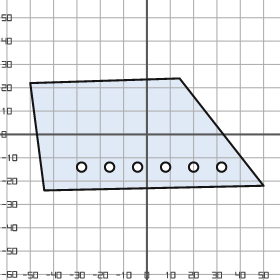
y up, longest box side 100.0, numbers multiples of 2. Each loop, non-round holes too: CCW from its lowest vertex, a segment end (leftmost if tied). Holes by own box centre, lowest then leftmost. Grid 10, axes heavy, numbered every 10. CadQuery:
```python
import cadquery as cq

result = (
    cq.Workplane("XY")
    .moveTo(-44.0, -24.0)
    .lineTo(50.0, -22.0)
    .lineTo(14.0, 24.0)
    .lineTo(-50.0, 22.0)
    .close()
    .moveTo(-28.0, -14.0)
    .circle(2.0)
    .moveTo(-16.0, -14.0)
    .circle(2.0)
    .moveTo(-4.0, -14.0)
    .circle(2.0)
    .moveTo(8.0, -14.0)
    .circle(2.0)
    .moveTo(20.0, -14.0)
    .circle(2.0)
    .moveTo(32.0, -14.0)
    .circle(2.0)
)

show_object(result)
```